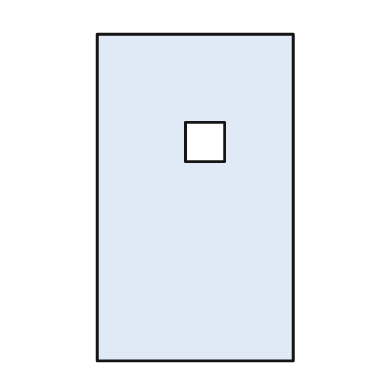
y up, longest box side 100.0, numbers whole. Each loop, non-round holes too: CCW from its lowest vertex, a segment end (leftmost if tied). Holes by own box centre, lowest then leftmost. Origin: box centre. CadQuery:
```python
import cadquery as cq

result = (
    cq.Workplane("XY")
    .moveTo(-30.0, -50.0)
    .lineTo(30.0, -50.0)
    .lineTo(30.0, 50.0)
    .lineTo(-30.0, 50.0)
    .close()
    .moveTo(-3.0, 11.0)
    .lineTo(9.0, 11.0)
    .lineTo(9.0, 23.0)
    .lineTo(-3.0, 23.0)
    .close()
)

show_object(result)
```